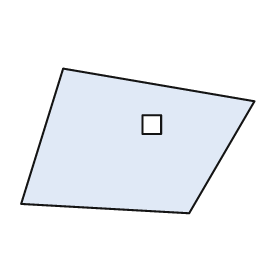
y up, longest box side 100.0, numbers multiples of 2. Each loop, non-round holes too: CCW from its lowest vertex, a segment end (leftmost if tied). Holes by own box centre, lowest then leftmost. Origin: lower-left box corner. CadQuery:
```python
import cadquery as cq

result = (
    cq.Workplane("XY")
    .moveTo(72.0, 0.0)
    .lineTo(100.0, 48.0)
    .lineTo(18.0, 62.0)
    .lineTo(0.0, 4.0)
    .close()
    .moveTo(52.0, 34.0)
    .lineTo(60.0, 34.0)
    .lineTo(60.0, 42.0)
    .lineTo(52.0, 42.0)
    .close()
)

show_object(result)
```